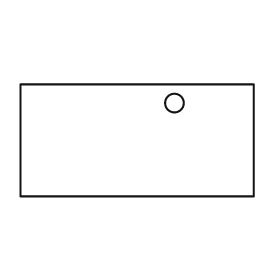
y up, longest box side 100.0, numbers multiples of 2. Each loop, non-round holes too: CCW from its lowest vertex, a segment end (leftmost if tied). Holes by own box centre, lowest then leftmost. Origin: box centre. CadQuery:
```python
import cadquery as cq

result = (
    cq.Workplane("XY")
    .moveTo(-50.0, -24.0)
    .lineTo(50.0, -24.0)
    .lineTo(50.0, 24.0)
    .lineTo(-50.0, 24.0)
    .close()
    .moveTo(16.0, 16.0)
    .circle(4.0)
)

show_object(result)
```